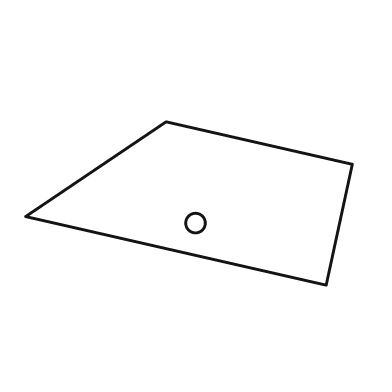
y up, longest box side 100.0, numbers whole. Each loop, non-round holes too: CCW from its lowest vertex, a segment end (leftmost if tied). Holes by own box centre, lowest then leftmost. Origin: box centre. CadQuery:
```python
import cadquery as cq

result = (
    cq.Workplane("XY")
    .moveTo(42.0, -25.0)
    .lineTo(50.0, 12.0)
    .lineTo(-7.0, 25.0)
    .lineTo(-50.0, -4.0)
    .close()
    .moveTo(2.0, -6.0)
    .circle(3.0)
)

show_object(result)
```